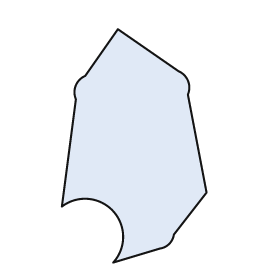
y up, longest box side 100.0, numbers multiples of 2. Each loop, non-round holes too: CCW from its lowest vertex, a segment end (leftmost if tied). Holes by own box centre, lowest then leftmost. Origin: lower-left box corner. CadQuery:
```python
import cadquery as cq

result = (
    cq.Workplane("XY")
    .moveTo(22.0, 0.0)
    .lineTo(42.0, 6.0)
    .threePointArc((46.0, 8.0), (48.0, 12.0))
    .lineTo(62.0, 30.0)
    .lineTo(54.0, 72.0)
    .threePointArc((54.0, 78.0), (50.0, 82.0))
    .lineTo(24.0, 100.0)
    .lineTo(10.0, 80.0)
    .threePointArc((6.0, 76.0), (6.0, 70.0))
    .lineTo(0.0, 24.0)
    .threePointArc((22.0, 22.0), (22.0, 0.0))
    .close()
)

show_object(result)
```